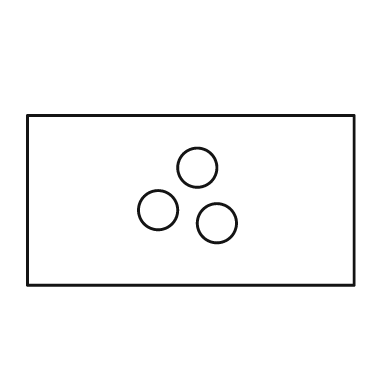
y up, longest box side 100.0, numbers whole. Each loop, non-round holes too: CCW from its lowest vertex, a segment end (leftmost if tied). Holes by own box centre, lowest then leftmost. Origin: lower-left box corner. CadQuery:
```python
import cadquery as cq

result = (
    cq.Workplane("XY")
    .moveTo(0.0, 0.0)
    .lineTo(100.0, 0.0)
    .lineTo(100.0, 52.0)
    .lineTo(0.0, 52.0)
    .close()
    .moveTo(58.0, 19.0)
    .circle(6.0)
    .moveTo(40.0, 23.0)
    .circle(6.0)
    .moveTo(52.0, 36.0)
    .circle(6.0)
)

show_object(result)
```